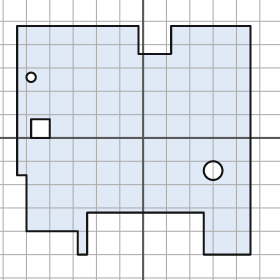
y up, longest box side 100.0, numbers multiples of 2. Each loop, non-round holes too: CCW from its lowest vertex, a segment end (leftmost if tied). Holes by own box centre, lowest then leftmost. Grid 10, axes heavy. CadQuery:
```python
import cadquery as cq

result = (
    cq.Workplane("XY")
    .moveTo(-28.0, -50.0)
    .lineTo(-24.0, -50.0)
    .lineTo(-24.0, -32.0)
    .lineTo(26.0, -32.0)
    .lineTo(26.0, -50.0)
    .lineTo(46.0, -50.0)
    .lineTo(46.0, 48.0)
    .lineTo(12.0, 48.0)
    .lineTo(12.0, 36.0)
    .lineTo(-2.0, 36.0)
    .lineTo(-2.0, 48.0)
    .lineTo(-54.0, 48.0)
    .lineTo(-54.0, -16.0)
    .lineTo(-50.0, -16.0)
    .lineTo(-50.0, -40.0)
    .lineTo(-28.0, -40.0)
    .close()
    .moveTo(30.0, -14.0)
    .circle(4.0)
    .moveTo(-48.0, 0.0)
    .lineTo(-40.0, 0.0)
    .lineTo(-40.0, 8.0)
    .lineTo(-48.0, 8.0)
    .close()
    .moveTo(-48.0, 26.0)
    .circle(2.0)
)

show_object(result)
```